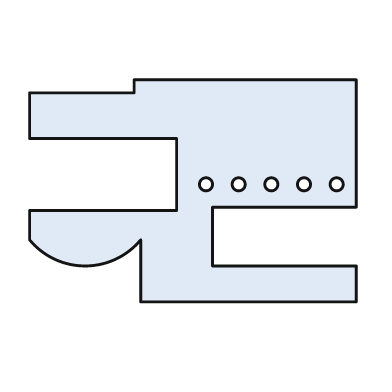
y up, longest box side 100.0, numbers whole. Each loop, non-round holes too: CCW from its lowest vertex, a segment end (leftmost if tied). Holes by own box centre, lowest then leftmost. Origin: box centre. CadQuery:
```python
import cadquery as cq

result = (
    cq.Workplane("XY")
    .moveTo(-16.0, -34.0)
    .lineTo(50.0, -34.0)
    .lineTo(50.0, -23.0)
    .lineTo(6.0, -23.0)
    .lineTo(6.0, -5.0)
    .lineTo(50.0, -5.0)
    .lineTo(50.0, 34.0)
    .lineTo(-18.0, 34.0)
    .lineTo(-18.0, 30.0)
    .lineTo(-50.0, 30.0)
    .lineTo(-50.0, 16.0)
    .lineTo(-5.0, 16.0)
    .lineTo(-5.0, -6.0)
    .lineTo(-50.0, -6.0)
    .lineTo(-50.0, -15.0)
    .threePointArc((-33.0, -23.0), (-16.0, -15.0))
    .close()
    .moveTo(4.0, 2.0)
    .circle(2.0)
    .moveTo(14.0, 2.0)
    .circle(2.0)
    .moveTo(24.0, 2.0)
    .circle(2.0)
    .moveTo(34.0, 2.0)
    .circle(2.0)
    .moveTo(44.0, 2.0)
    .circle(2.0)
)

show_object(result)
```